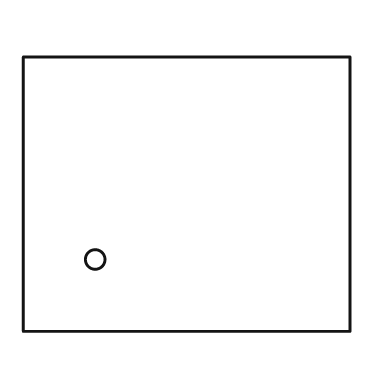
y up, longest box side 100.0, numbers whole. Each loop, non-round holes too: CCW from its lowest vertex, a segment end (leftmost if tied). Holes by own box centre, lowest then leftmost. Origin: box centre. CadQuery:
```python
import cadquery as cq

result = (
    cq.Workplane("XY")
    .moveTo(-50.0, -42.0)
    .lineTo(50.0, -42.0)
    .lineTo(50.0, 42.0)
    .lineTo(-50.0, 42.0)
    .close()
    .moveTo(-28.0, -20.0)
    .circle(3.0)
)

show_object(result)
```